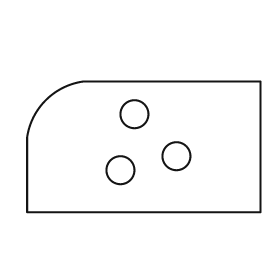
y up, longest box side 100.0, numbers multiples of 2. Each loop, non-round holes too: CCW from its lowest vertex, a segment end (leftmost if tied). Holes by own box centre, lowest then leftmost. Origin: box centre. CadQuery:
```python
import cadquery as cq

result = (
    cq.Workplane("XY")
    .moveTo(-50.0, -28.0)
    .lineTo(50.0, -28.0)
    .lineTo(50.0, 28.0)
    .lineTo(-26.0, 28.0)
    .threePointArc((-42.0, 20.0), (-50.0, 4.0))
    .close()
    .moveTo(-10.0, -10.0)
    .circle(6.0)
    .moveTo(14.0, -4.0)
    .circle(6.0)
    .moveTo(-4.0, 14.0)
    .circle(6.0)
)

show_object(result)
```